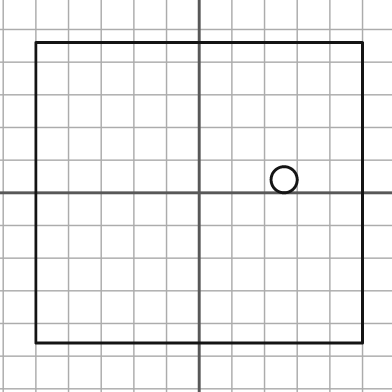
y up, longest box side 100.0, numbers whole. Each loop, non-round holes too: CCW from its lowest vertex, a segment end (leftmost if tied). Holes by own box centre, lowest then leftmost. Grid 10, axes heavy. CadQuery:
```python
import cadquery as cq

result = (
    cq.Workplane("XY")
    .moveTo(-50.0, -46.0)
    .lineTo(50.0, -46.0)
    .lineTo(50.0, 46.0)
    .lineTo(-50.0, 46.0)
    .close()
    .moveTo(26.0, 4.0)
    .circle(4.0)
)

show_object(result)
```